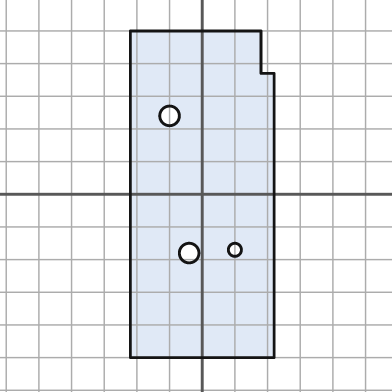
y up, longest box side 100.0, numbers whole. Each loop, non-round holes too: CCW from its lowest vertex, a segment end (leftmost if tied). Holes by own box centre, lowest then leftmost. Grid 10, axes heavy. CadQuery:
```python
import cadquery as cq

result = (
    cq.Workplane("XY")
    .moveTo(-22.0, -50.0)
    .lineTo(22.0, -50.0)
    .lineTo(22.0, 37.0)
    .lineTo(18.0, 37.0)
    .lineTo(18.0, 50.0)
    .lineTo(-22.0, 50.0)
    .close()
    .moveTo(-4.0, -18.0)
    .circle(3.0)
    .moveTo(10.0, -17.0)
    .circle(2.0)
    .moveTo(-10.0, 24.0)
    .circle(3.0)
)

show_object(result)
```